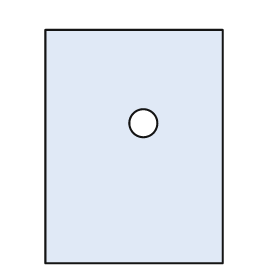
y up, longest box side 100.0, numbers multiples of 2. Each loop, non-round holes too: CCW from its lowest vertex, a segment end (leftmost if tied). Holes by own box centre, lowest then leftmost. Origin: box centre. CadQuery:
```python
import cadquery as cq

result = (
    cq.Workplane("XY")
    .moveTo(-38.0, -50.0)
    .lineTo(38.0, -50.0)
    .lineTo(38.0, 50.0)
    .lineTo(-38.0, 50.0)
    .close()
    .moveTo(4.0, 10.0)
    .circle(6.0)
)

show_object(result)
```